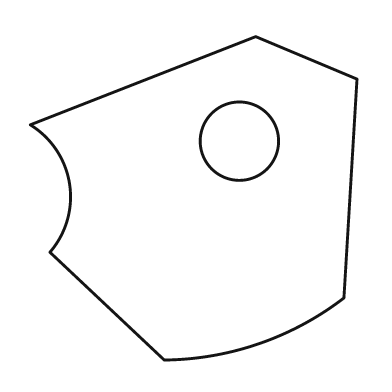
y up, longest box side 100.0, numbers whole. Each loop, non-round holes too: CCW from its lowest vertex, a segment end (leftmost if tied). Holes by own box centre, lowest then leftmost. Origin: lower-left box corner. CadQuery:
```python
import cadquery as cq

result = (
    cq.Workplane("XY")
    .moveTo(41.0, 0.0)
    .threePointArc((70.0, 5.0), (96.0, 19.0))
    .lineTo(100.0, 86.0)
    .lineTo(69.0, 99.0)
    .lineTo(0.0, 72.0)
    .threePointArc((12.0, 54.0), (6.0, 33.0))
    .close()
    .moveTo(64.0, 67.0)
    .circle(12.0)
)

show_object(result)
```